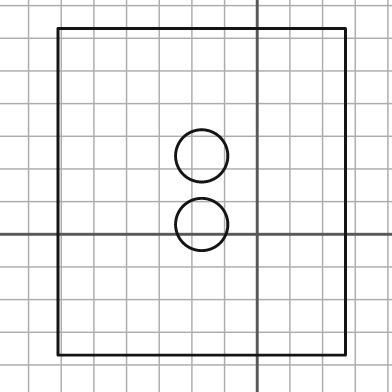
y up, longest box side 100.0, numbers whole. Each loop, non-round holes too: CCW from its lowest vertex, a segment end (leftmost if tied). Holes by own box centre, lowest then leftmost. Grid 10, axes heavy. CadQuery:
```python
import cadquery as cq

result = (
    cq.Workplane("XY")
    .moveTo(-61.0, -37.0)
    .lineTo(27.0, -37.0)
    .lineTo(27.0, 63.0)
    .lineTo(-61.0, 63.0)
    .close()
    .moveTo(-17.0, 3.0)
    .circle(8.0)
    .moveTo(-17.0, 24.0)
    .circle(8.0)
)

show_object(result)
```